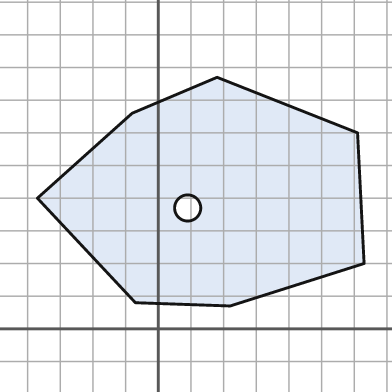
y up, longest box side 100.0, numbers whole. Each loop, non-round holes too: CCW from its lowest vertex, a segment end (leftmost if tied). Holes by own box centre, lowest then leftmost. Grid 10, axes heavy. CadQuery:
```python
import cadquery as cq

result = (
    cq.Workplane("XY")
    .moveTo(22.0, 7.0)
    .lineTo(63.0, 20.0)
    .lineTo(61.0, 60.0)
    .lineTo(18.0, 77.0)
    .lineTo(-8.0, 66.0)
    .lineTo(-37.0, 40.0)
    .lineTo(-7.0, 8.0)
    .close()
    .moveTo(9.0, 37.0)
    .circle(4.0)
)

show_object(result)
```